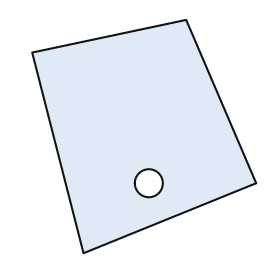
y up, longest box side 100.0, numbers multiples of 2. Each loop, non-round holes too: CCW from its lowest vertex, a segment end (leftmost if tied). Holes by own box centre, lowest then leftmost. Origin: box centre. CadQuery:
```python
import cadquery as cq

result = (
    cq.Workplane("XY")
    .moveTo(-26.0, -50.0)
    .lineTo(48.0, -20.0)
    .lineTo(18.0, 50.0)
    .lineTo(-48.0, 36.0)
    .close()
    .moveTo(2.0, -20.0)
    .circle(6.0)
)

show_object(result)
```